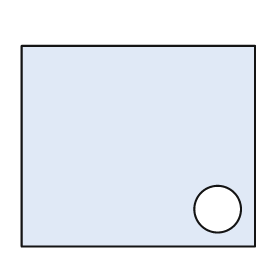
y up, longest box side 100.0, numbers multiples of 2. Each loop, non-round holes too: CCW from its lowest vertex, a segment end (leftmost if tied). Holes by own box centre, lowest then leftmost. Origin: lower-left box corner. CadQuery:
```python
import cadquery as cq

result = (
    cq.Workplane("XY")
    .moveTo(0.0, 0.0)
    .lineTo(100.0, 0.0)
    .lineTo(100.0, 86.0)
    .lineTo(0.0, 86.0)
    .close()
    .moveTo(84.0, 16.0)
    .circle(10.0)
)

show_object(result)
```